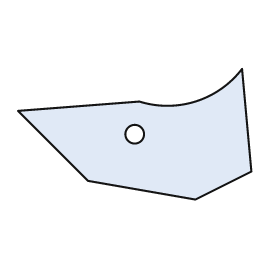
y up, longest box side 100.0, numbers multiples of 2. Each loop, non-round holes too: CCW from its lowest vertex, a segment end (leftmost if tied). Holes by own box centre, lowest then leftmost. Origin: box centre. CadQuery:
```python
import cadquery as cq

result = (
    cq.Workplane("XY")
    .moveTo(26.0, -28.0)
    .lineTo(50.0, -16.0)
    .lineTo(46.0, 28.0)
    .threePointArc((26.0, 14.0), (2.0, 14.0))
    .lineTo(-50.0, 10.0)
    .lineTo(-20.0, -20.0)
    .close()
    .moveTo(0.0, 0.0)
    .circle(4.0)
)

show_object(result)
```